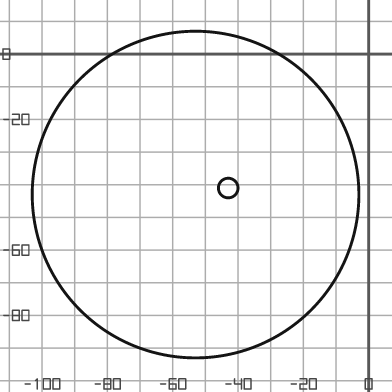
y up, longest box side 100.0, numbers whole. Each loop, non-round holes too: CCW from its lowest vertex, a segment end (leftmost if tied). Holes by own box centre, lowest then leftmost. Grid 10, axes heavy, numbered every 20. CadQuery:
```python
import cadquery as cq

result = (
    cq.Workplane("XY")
    .moveTo(-53.0, -43.0)
    .circle(50.0)
    .moveTo(-43.0, -41.0)
    .circle(3.0)
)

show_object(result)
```